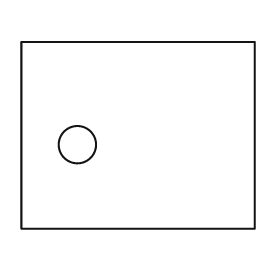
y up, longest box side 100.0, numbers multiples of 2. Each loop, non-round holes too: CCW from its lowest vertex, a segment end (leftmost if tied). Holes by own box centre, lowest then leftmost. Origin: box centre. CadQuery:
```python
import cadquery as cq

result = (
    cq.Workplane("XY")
    .moveTo(-50.0, -40.0)
    .lineTo(50.0, -40.0)
    .lineTo(50.0, 40.0)
    .lineTo(-50.0, 40.0)
    .close()
    .moveTo(-26.0, -4.0)
    .circle(8.0)
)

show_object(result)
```